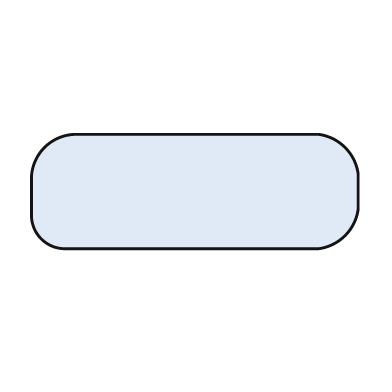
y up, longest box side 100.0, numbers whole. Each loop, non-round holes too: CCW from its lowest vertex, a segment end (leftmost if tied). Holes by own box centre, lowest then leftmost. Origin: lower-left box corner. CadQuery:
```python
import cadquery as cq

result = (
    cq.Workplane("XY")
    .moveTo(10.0, 0.0)
    .lineTo(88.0, 0.0)
    .threePointArc((96.0, 4.0), (100.0, 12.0))
    .lineTo(100.0, 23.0)
    .threePointArc((96.0, 31.0), (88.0, 35.0))
    .lineTo(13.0, 35.0)
    .threePointArc((4.0, 31.0), (0.0, 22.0))
    .lineTo(0.0, 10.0)
    .threePointArc((3.0, 3.0), (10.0, 0.0))
    .close()
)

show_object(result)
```